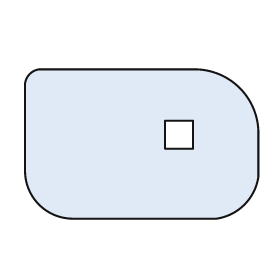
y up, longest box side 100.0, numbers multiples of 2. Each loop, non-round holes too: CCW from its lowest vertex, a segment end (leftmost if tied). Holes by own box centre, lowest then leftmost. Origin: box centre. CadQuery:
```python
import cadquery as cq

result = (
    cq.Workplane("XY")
    .moveTo(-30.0, -32.0)
    .lineTo(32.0, -32.0)
    .threePointArc((44.0, -26.0), (50.0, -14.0))
    .lineTo(50.0, 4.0)
    .threePointArc((42.0, 24.0), (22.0, 32.0))
    .lineTo(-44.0, 32.0)
    .threePointArc((-48.0, 30.0), (-50.0, 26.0))
    .lineTo(-50.0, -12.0)
    .threePointArc((-44.0, -26.0), (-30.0, -32.0))
    .close()
    .moveTo(10.0, -2.0)
    .lineTo(22.0, -2.0)
    .lineTo(22.0, 10.0)
    .lineTo(10.0, 10.0)
    .close()
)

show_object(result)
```